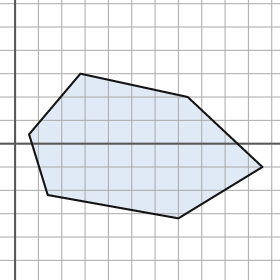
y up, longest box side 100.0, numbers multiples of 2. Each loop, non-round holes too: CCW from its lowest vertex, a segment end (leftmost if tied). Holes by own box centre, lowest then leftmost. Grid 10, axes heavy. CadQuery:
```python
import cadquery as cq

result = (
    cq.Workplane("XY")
    .moveTo(70.0, -32.0)
    .lineTo(106.0, -10.0)
    .lineTo(74.0, 20.0)
    .lineTo(28.0, 30.0)
    .lineTo(6.0, 4.0)
    .lineTo(14.0, -22.0)
    .close()
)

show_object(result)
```